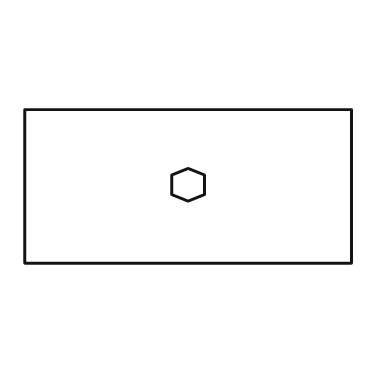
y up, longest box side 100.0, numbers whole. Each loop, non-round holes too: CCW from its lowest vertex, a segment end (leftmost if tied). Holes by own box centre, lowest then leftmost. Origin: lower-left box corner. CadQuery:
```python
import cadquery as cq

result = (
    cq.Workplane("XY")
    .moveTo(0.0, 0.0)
    .lineTo(100.0, 0.0)
    .lineTo(100.0, 47.0)
    .lineTo(0.0, 47.0)
    .close()
    .moveTo(50.0, 19.0)
    .lineTo(55.0, 21.0)
    .lineTo(55.0, 27.0)
    .lineTo(50.0, 29.0)
    .lineTo(45.0, 27.0)
    .lineTo(45.0, 21.0)
    .close()
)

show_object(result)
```